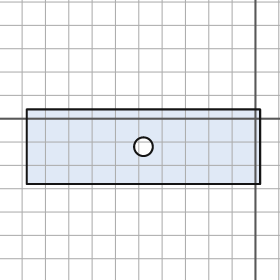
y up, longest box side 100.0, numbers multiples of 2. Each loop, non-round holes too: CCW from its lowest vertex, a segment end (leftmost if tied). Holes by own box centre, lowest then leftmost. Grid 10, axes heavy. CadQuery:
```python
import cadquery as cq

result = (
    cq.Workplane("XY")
    .moveTo(-98.0, -28.0)
    .lineTo(2.0, -28.0)
    .lineTo(2.0, 4.0)
    .lineTo(-98.0, 4.0)
    .close()
    .moveTo(-48.0, -12.0)
    .circle(4.0)
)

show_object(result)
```